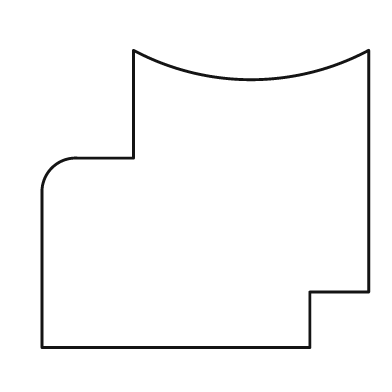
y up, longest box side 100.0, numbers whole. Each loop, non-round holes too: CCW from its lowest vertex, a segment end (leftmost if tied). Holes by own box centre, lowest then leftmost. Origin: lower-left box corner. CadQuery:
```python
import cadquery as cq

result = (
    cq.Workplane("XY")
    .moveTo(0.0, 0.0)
    .lineTo(82.0, 0.0)
    .lineTo(82.0, 17.0)
    .lineTo(100.0, 17.0)
    .lineTo(100.0, 91.0)
    .threePointArc((64.0, 82.0), (28.0, 91.0))
    .lineTo(28.0, 58.0)
    .lineTo(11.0, 58.0)
    .threePointArc((3.0, 55.0), (0.0, 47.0))
    .close()
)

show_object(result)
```